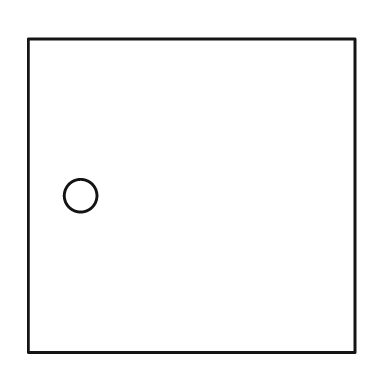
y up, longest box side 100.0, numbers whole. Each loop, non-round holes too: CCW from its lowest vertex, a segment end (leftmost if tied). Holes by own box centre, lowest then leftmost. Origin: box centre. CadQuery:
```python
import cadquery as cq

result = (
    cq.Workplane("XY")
    .moveTo(-50.0, -48.0)
    .lineTo(50.0, -48.0)
    .lineTo(50.0, 48.0)
    .lineTo(-50.0, 48.0)
    .close()
    .moveTo(-34.0, 0.0)
    .circle(5.0)
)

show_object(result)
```